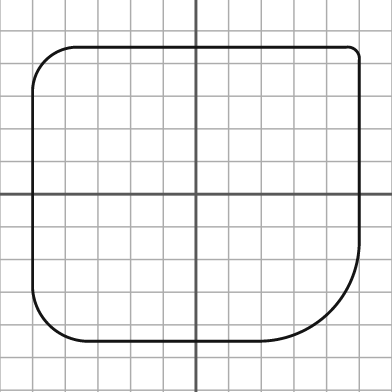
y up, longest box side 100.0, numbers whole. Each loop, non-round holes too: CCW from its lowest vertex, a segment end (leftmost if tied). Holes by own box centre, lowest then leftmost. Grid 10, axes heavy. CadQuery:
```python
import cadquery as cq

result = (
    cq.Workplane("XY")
    .moveTo(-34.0, -45.0)
    .lineTo(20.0, -45.0)
    .threePointArc((41.0, -36.0), (50.0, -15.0))
    .lineTo(50.0, 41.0)
    .threePointArc((49.0, 44.0), (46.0, 45.0))
    .lineTo(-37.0, 45.0)
    .threePointArc((-46.0, 41.0), (-50.0, 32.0))
    .lineTo(-50.0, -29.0)
    .threePointArc((-45.0, -40.0), (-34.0, -45.0))
    .close()
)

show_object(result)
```